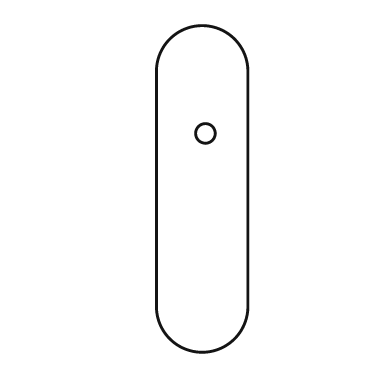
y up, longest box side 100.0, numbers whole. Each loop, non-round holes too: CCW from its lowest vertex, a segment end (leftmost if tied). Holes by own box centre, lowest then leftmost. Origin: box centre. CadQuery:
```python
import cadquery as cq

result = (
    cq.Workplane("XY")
    .moveTo(-14.0, -36.0)
    .threePointArc((0.0, -50.0), (14.0, -36.0))
    .lineTo(14.0, 36.0)
    .threePointArc((0.0, 50.0), (-14.0, 36.0))
    .close()
    .moveTo(1.0, 17.0)
    .circle(3.0)
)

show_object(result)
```